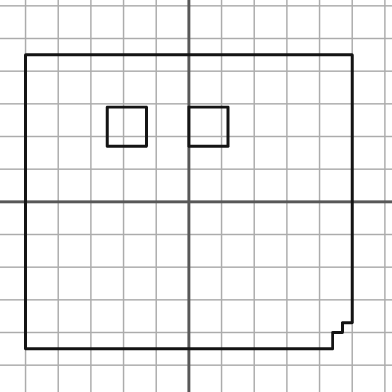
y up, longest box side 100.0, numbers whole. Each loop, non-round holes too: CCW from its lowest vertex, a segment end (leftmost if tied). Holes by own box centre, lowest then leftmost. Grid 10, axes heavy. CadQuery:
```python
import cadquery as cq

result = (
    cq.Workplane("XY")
    .moveTo(-50.0, -45.0)
    .lineTo(44.0, -45.0)
    .lineTo(44.0, -40.0)
    .lineTo(47.0, -40.0)
    .lineTo(47.0, -37.0)
    .lineTo(50.0, -37.0)
    .lineTo(50.0, 45.0)
    .lineTo(-50.0, 45.0)
    .close()
    .moveTo(-25.0, 17.0)
    .lineTo(-13.0, 17.0)
    .lineTo(-13.0, 29.0)
    .lineTo(-25.0, 29.0)
    .close()
    .moveTo(0.0, 17.0)
    .lineTo(12.0, 17.0)
    .lineTo(12.0, 29.0)
    .lineTo(0.0, 29.0)
    .close()
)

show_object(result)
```